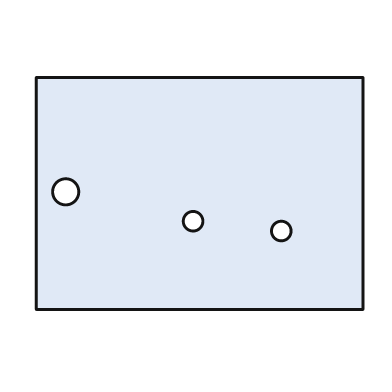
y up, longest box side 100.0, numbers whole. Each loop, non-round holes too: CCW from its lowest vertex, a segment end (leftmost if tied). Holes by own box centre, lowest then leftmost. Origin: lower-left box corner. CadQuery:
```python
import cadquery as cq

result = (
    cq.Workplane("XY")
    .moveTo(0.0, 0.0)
    .lineTo(100.0, 0.0)
    .lineTo(100.0, 71.0)
    .lineTo(0.0, 71.0)
    .close()
    .moveTo(75.0, 24.0)
    .circle(3.0)
    .moveTo(48.0, 27.0)
    .circle(3.0)
    .moveTo(9.0, 36.0)
    .circle(4.0)
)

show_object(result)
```